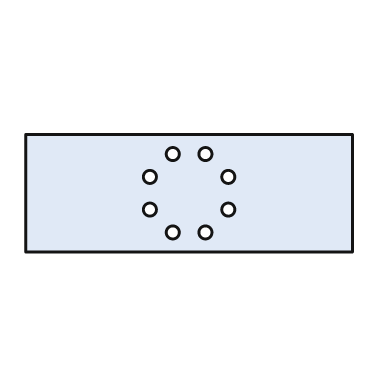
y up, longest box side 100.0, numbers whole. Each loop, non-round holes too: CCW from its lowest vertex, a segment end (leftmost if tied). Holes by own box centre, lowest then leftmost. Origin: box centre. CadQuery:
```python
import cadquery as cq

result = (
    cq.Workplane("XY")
    .moveTo(-50.0, -18.0)
    .lineTo(50.0, -18.0)
    .lineTo(50.0, 18.0)
    .lineTo(-50.0, 18.0)
    .close()
    .moveTo(-5.0, -12.0)
    .circle(2.0)
    .moveTo(5.0, -12.0)
    .circle(2.0)
    .moveTo(-12.0, -5.0)
    .circle(2.0)
    .moveTo(12.0, -5.0)
    .circle(2.0)
    .moveTo(-12.0, 5.0)
    .circle(2.0)
    .moveTo(12.0, 5.0)
    .circle(2.0)
    .moveTo(-5.0, 12.0)
    .circle(2.0)
    .moveTo(5.0, 12.0)
    .circle(2.0)
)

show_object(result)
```